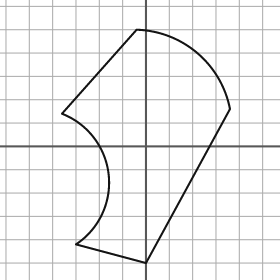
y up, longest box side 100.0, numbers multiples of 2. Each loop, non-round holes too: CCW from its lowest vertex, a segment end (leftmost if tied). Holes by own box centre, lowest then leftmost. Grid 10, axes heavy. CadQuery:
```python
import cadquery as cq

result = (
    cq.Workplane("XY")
    .moveTo(0.0, -50.0)
    .lineTo(36.0, 16.0)
    .threePointArc((22.0, 40.0), (-4.0, 50.0))
    .lineTo(-36.0, 14.0)
    .threePointArc((-16.0, -12.0), (-30.0, -42.0))
    .close()
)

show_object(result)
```